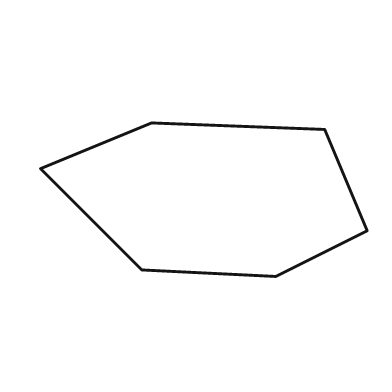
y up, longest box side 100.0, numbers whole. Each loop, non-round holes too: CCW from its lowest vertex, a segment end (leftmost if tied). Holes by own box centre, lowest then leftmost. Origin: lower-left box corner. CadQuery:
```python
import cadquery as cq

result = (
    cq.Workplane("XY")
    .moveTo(72.0, 0.0)
    .lineTo(100.0, 14.0)
    .lineTo(87.0, 45.0)
    .lineTo(34.0, 47.0)
    .lineTo(0.0, 33.0)
    .lineTo(31.0, 2.0)
    .close()
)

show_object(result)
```